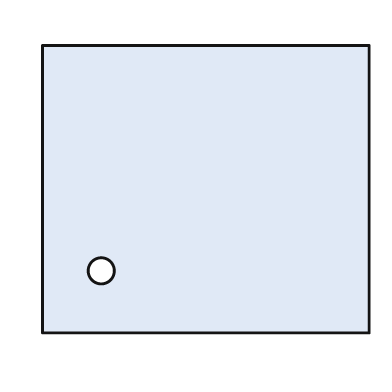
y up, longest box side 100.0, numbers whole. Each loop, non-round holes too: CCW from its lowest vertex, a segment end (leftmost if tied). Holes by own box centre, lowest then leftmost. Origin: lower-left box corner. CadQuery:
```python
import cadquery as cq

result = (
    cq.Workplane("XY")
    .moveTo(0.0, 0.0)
    .lineTo(100.0, 0.0)
    .lineTo(100.0, 88.0)
    .lineTo(0.0, 88.0)
    .close()
    .moveTo(18.0, 19.0)
    .circle(4.0)
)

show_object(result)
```